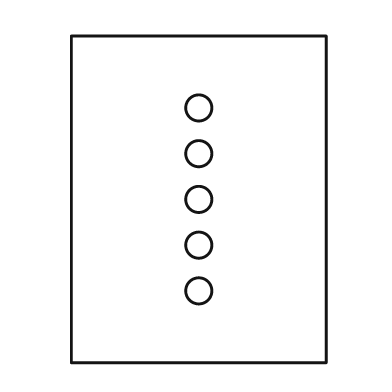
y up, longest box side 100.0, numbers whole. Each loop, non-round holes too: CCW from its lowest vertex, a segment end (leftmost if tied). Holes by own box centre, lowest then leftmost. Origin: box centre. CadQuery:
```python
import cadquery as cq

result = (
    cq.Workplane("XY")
    .moveTo(-39.0, -50.0)
    .lineTo(39.0, -50.0)
    .lineTo(39.0, 50.0)
    .lineTo(-39.0, 50.0)
    .close()
    .moveTo(0.0, -28.0)
    .circle(4.0)
    .moveTo(0.0, -14.0)
    .circle(4.0)
    .moveTo(0.0, 0.0)
    .circle(4.0)
    .moveTo(0.0, 14.0)
    .circle(4.0)
    .moveTo(0.0, 28.0)
    .circle(4.0)
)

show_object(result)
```